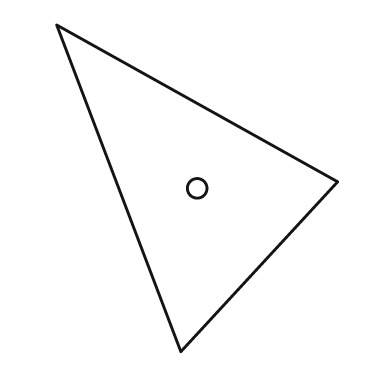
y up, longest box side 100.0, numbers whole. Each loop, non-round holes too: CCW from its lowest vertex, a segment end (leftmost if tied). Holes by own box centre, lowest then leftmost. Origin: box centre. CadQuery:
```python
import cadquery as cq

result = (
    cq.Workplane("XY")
    .moveTo(-5.0, -50.0)
    .lineTo(43.0, 2.0)
    .lineTo(-43.0, 50.0)
    .close()
    .moveTo(0.0, 0.0)
    .circle(3.0)
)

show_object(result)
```